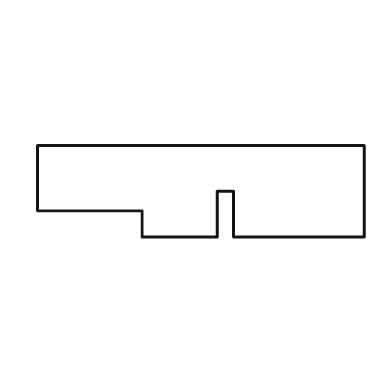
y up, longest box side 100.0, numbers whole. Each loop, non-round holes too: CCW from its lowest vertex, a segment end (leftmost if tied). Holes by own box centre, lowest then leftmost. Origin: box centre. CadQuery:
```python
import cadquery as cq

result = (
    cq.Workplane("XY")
    .moveTo(-18.0, -14.0)
    .lineTo(5.0, -14.0)
    .lineTo(5.0, 0.0)
    .lineTo(10.0, 0.0)
    .lineTo(10.0, -14.0)
    .lineTo(50.0, -14.0)
    .lineTo(50.0, 14.0)
    .lineTo(-50.0, 14.0)
    .lineTo(-50.0, -6.0)
    .lineTo(-18.0, -6.0)
    .close()
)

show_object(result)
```